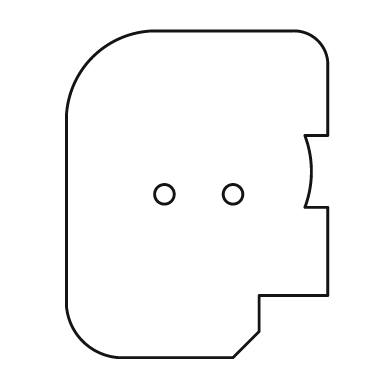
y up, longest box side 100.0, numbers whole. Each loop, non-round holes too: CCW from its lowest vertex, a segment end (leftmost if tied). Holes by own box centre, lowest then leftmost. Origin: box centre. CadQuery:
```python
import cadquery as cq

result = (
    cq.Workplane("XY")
    .moveTo(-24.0, -50.0)
    .lineTo(11.0, -50.0)
    .lineTo(19.0, -42.0)
    .lineTo(19.0, -31.0)
    .lineTo(40.0, -31.0)
    .lineTo(40.0, -4.0)
    .lineTo(33.0, -4.0)
    .threePointArc((35.0, 7.0), (33.0, 18.0))
    .lineTo(40.0, 18.0)
    .lineTo(40.0, 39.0)
    .threePointArc((37.0, 47.0), (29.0, 50.0))
    .lineTo(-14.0, 50.0)
    .threePointArc((-32.0, 42.0), (-40.0, 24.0))
    .lineTo(-40.0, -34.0)
    .threePointArc((-35.0, -45.0), (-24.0, -50.0))
    .close()
    .moveTo(-10.0, 0.0)
    .circle(3.0)
    .moveTo(11.0, 0.0)
    .circle(3.0)
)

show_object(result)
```